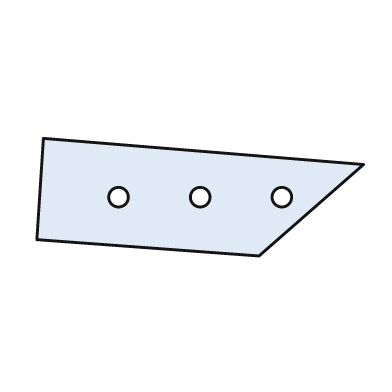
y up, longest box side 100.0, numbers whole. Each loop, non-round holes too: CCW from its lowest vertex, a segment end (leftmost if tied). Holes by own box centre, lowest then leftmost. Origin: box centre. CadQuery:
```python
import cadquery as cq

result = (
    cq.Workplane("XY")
    .moveTo(18.0, -18.0)
    .lineTo(50.0, 10.0)
    .lineTo(-48.0, 18.0)
    .lineTo(-50.0, -13.0)
    .close()
    .moveTo(-25.0, 0.0)
    .circle(3.0)
    .moveTo(0.0, 0.0)
    .circle(3.0)
    .moveTo(25.0, 0.0)
    .circle(3.0)
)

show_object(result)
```